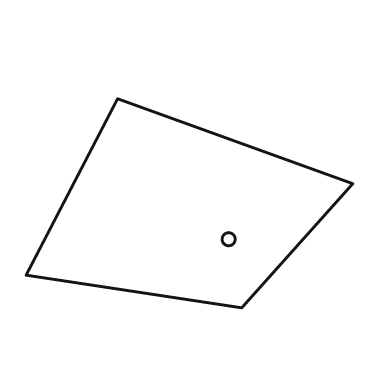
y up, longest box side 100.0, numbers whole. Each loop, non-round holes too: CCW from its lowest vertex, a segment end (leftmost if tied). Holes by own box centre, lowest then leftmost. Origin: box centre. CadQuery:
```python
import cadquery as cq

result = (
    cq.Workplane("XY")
    .moveTo(16.0, -32.0)
    .lineTo(50.0, 6.0)
    .lineTo(-22.0, 32.0)
    .lineTo(-50.0, -22.0)
    .close()
    .moveTo(12.0, -11.0)
    .circle(2.0)
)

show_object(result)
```